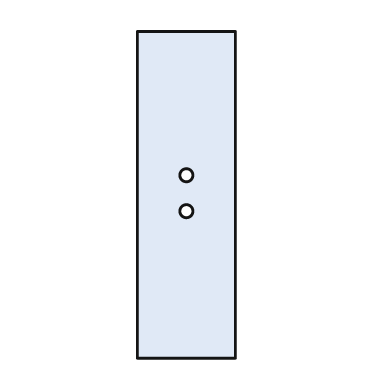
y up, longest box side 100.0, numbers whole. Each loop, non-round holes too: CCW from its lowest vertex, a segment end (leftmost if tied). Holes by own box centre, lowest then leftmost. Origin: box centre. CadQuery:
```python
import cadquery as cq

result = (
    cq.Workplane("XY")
    .moveTo(-15.0, -50.0)
    .lineTo(15.0, -50.0)
    .lineTo(15.0, 50.0)
    .lineTo(-15.0, 50.0)
    .close()
    .moveTo(0.0, -5.0)
    .circle(2.0)
    .moveTo(0.0, 6.0)
    .circle(2.0)
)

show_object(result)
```